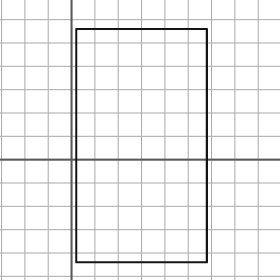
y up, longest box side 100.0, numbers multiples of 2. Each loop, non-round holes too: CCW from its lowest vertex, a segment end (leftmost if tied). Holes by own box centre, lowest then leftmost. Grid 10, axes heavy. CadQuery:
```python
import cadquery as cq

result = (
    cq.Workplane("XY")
    .moveTo(2.0, -44.0)
    .lineTo(58.0, -44.0)
    .lineTo(58.0, 56.0)
    .lineTo(2.0, 56.0)
    .close()
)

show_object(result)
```